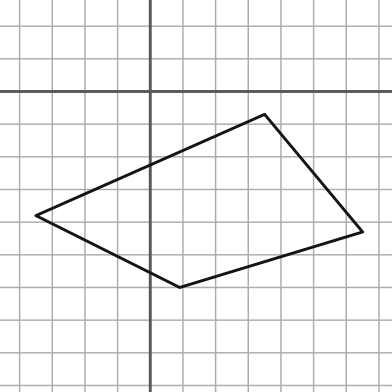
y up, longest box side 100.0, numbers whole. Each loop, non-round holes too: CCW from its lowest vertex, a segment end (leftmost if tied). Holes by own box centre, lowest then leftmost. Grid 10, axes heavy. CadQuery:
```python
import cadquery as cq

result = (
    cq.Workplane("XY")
    .moveTo(9.0, -60.0)
    .lineTo(65.0, -43.0)
    .lineTo(35.0, -7.0)
    .lineTo(-35.0, -38.0)
    .close()
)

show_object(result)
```